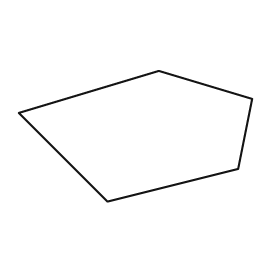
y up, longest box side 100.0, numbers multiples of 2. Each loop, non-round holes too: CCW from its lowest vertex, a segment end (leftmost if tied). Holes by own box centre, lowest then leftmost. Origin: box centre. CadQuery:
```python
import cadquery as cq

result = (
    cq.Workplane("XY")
    .moveTo(-12.0, -28.0)
    .lineTo(44.0, -14.0)
    .lineTo(50.0, 16.0)
    .lineTo(10.0, 28.0)
    .lineTo(-50.0, 10.0)
    .close()
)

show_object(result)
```